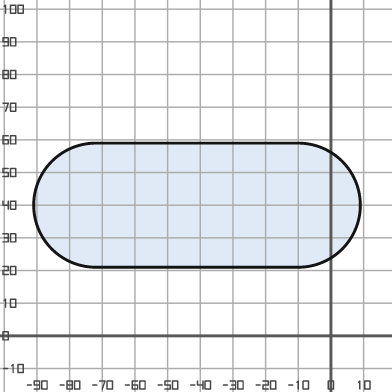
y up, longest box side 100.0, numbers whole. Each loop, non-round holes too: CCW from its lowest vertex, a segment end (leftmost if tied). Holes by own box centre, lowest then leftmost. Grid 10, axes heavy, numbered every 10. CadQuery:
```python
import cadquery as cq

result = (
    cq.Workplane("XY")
    .moveTo(-72.0, 21.0)
    .lineTo(-10.0, 21.0)
    .threePointArc((9.0, 40.0), (-10.0, 59.0))
    .lineTo(-72.0, 59.0)
    .threePointArc((-91.0, 40.0), (-72.0, 21.0))
    .close()
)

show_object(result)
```